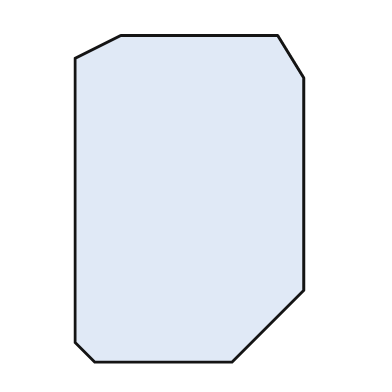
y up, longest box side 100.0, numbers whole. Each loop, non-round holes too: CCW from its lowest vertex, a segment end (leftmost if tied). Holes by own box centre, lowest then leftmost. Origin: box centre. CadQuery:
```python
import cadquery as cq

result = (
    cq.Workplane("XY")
    .moveTo(-29.0, -50.0)
    .lineTo(13.0, -50.0)
    .lineTo(35.0, -28.0)
    .lineTo(35.0, 37.0)
    .lineTo(27.0, 50.0)
    .lineTo(-21.0, 50.0)
    .lineTo(-35.0, 43.0)
    .lineTo(-35.0, -44.0)
    .close()
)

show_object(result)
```